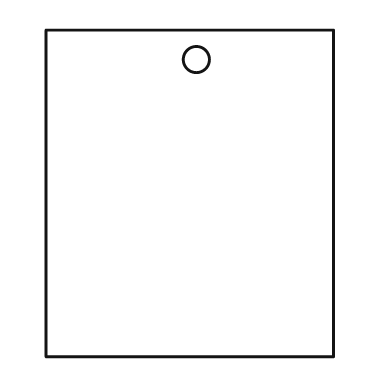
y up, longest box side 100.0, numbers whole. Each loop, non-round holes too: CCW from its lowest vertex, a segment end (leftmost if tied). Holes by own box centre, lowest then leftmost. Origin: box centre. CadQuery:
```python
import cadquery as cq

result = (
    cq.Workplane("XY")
    .moveTo(-44.0, -50.0)
    .lineTo(44.0, -50.0)
    .lineTo(44.0, 50.0)
    .lineTo(-44.0, 50.0)
    .close()
    .moveTo(2.0, 41.0)
    .circle(4.0)
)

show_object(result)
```